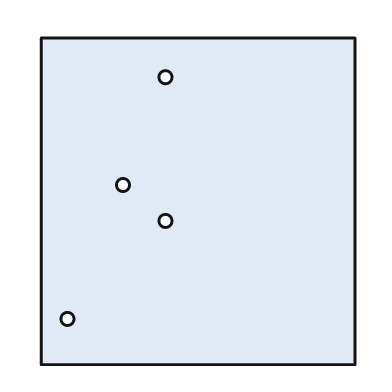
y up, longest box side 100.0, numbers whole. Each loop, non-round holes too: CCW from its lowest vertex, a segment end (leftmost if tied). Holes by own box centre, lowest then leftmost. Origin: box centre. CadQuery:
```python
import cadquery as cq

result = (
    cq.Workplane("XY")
    .moveTo(-48.0, -50.0)
    .lineTo(48.0, -50.0)
    .lineTo(48.0, 50.0)
    .lineTo(-48.0, 50.0)
    .close()
    .moveTo(-40.0, -36.0)
    .circle(2.0)
    .moveTo(-10.0, -6.0)
    .circle(2.0)
    .moveTo(-23.0, 5.0)
    .circle(2.0)
    .moveTo(-10.0, 38.0)
    .circle(2.0)
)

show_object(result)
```